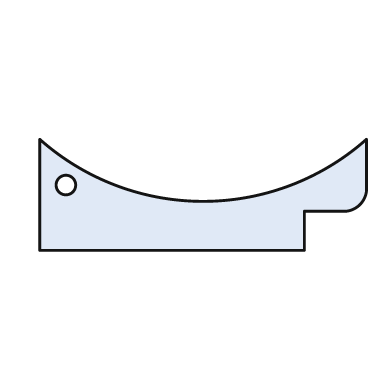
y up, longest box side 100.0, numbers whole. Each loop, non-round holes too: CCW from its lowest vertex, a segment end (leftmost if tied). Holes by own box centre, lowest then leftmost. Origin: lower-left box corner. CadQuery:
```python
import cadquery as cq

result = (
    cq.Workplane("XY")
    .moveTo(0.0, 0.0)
    .lineTo(81.0, 0.0)
    .lineTo(81.0, 12.0)
    .lineTo(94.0, 12.0)
    .threePointArc((98.0, 14.0), (100.0, 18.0))
    .lineTo(100.0, 34.0)
    .threePointArc((50.0, 15.0), (0.0, 34.0))
    .close()
    .moveTo(8.0, 20.0)
    .circle(3.0)
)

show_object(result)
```